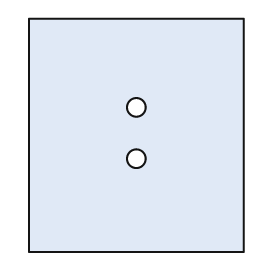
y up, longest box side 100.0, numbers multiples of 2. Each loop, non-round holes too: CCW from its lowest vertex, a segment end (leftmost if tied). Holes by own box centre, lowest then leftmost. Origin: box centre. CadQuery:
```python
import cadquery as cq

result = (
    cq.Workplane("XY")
    .moveTo(-46.0, -50.0)
    .lineTo(46.0, -50.0)
    .lineTo(46.0, 50.0)
    .lineTo(-46.0, 50.0)
    .close()
    .moveTo(0.0, -10.0)
    .circle(4.0)
    .moveTo(0.0, 12.0)
    .circle(4.0)
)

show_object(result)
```